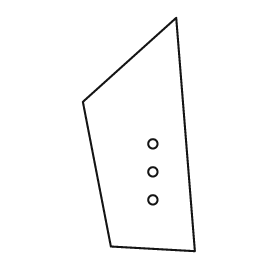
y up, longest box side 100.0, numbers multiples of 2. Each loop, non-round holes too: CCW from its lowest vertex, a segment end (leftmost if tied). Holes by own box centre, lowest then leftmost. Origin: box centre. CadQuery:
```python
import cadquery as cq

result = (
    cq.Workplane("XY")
    .moveTo(24.0, -50.0)
    .lineTo(16.0, 50.0)
    .lineTo(-24.0, 14.0)
    .lineTo(-12.0, -48.0)
    .close()
    .moveTo(6.0, -28.0)
    .circle(2.0)
    .moveTo(6.0, -16.0)
    .circle(2.0)
    .moveTo(6.0, -4.0)
    .circle(2.0)
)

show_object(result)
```